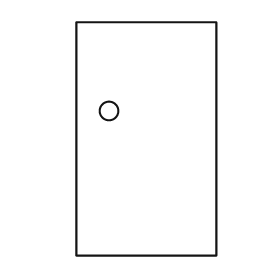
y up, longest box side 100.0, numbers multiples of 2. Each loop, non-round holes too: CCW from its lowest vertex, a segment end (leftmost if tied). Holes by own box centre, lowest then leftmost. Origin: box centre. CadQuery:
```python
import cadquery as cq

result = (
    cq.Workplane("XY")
    .moveTo(-30.0, -50.0)
    .lineTo(30.0, -50.0)
    .lineTo(30.0, 50.0)
    .lineTo(-30.0, 50.0)
    .close()
    .moveTo(-16.0, 12.0)
    .circle(4.0)
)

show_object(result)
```